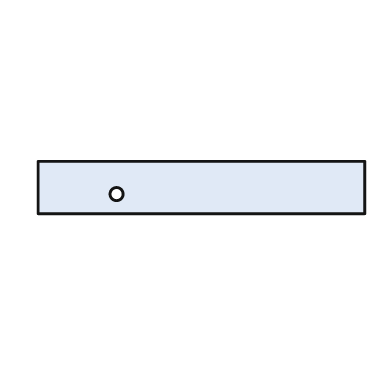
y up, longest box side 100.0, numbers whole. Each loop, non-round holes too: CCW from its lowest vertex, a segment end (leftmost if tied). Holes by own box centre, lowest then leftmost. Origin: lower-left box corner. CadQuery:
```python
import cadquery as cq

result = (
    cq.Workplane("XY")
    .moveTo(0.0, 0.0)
    .lineTo(100.0, 0.0)
    .lineTo(100.0, 16.0)
    .lineTo(0.0, 16.0)
    .close()
    .moveTo(24.0, 6.0)
    .circle(2.0)
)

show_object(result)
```